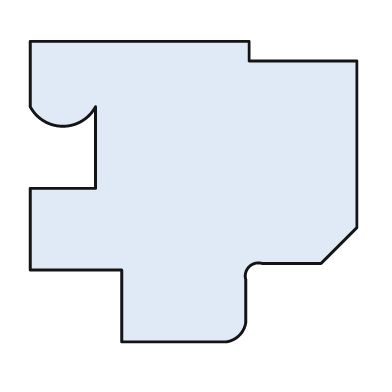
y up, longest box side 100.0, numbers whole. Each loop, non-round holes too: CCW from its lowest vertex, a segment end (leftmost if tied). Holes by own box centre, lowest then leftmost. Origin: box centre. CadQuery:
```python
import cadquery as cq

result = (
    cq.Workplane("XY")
    .moveTo(-22.0, -46.0)
    .lineTo(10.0, -46.0)
    .threePointArc((14.0, -44.0), (16.0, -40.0))
    .lineTo(16.0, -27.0)
    .threePointArc((17.0, -23.0), (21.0, -22.0))
    .lineTo(39.0, -22.0)
    .lineTo(50.0, -11.0)
    .lineTo(50.0, 40.0)
    .lineTo(17.0, 40.0)
    .lineTo(17.0, 46.0)
    .lineTo(-50.0, 46.0)
    .lineTo(-50.0, 26.0)
    .threePointArc((-40.0, 20.0), (-30.0, 26.0))
    .lineTo(-30.0, 1.0)
    .lineTo(-50.0, 1.0)
    .lineTo(-50.0, -24.0)
    .lineTo(-22.0, -24.0)
    .close()
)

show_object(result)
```